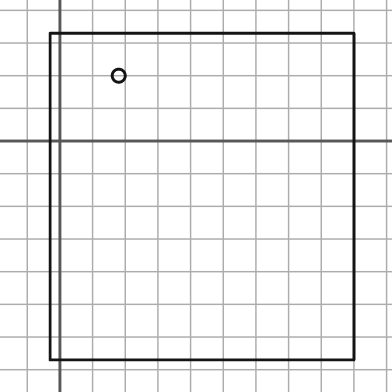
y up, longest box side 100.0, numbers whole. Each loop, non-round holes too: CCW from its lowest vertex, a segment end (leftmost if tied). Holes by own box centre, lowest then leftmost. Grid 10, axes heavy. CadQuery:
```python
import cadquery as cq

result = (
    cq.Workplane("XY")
    .moveTo(-3.0, -67.0)
    .lineTo(90.0, -67.0)
    .lineTo(90.0, 33.0)
    .lineTo(-3.0, 33.0)
    .close()
    .moveTo(18.0, 20.0)
    .circle(2.0)
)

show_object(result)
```